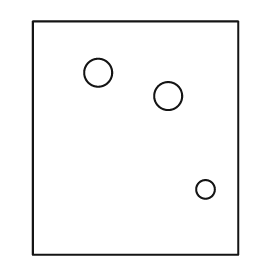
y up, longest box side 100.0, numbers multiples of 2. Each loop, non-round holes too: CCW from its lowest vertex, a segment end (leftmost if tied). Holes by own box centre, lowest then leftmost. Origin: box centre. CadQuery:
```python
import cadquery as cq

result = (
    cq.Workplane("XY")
    .moveTo(-44.0, -50.0)
    .lineTo(44.0, -50.0)
    .lineTo(44.0, 50.0)
    .lineTo(-44.0, 50.0)
    .close()
    .moveTo(30.0, -22.0)
    .circle(4.0)
    .moveTo(14.0, 18.0)
    .circle(6.0)
    .moveTo(-16.0, 28.0)
    .circle(6.0)
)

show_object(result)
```